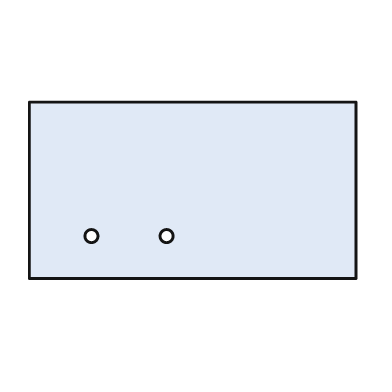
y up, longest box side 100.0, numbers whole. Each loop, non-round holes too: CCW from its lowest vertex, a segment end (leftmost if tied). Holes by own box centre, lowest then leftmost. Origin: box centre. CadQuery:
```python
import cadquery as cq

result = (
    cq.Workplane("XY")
    .moveTo(-50.0, -27.0)
    .lineTo(50.0, -27.0)
    .lineTo(50.0, 27.0)
    .lineTo(-50.0, 27.0)
    .close()
    .moveTo(-31.0, -14.0)
    .circle(2.0)
    .moveTo(-8.0, -14.0)
    .circle(2.0)
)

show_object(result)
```